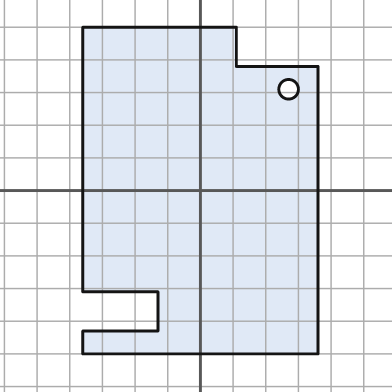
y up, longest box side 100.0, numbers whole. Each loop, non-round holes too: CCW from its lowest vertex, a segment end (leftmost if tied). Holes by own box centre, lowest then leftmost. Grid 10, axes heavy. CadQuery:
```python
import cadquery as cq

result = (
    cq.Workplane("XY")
    .moveTo(-36.0, -50.0)
    .lineTo(36.0, -50.0)
    .lineTo(36.0, 38.0)
    .lineTo(11.0, 38.0)
    .lineTo(11.0, 50.0)
    .lineTo(-36.0, 50.0)
    .lineTo(-36.0, -31.0)
    .lineTo(-13.0, -31.0)
    .lineTo(-13.0, -43.0)
    .lineTo(-36.0, -43.0)
    .close()
    .moveTo(27.0, 31.0)
    .circle(3.0)
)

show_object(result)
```